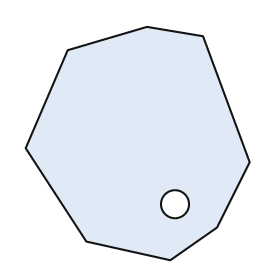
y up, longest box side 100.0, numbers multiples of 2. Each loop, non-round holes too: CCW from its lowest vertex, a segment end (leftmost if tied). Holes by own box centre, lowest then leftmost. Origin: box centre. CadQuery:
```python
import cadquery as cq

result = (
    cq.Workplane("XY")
    .moveTo(14.0, -50.0)
    .lineTo(34.0, -36.0)
    .lineTo(48.0, -8.0)
    .lineTo(28.0, 46.0)
    .lineTo(4.0, 50.0)
    .lineTo(-30.0, 40.0)
    .lineTo(-48.0, -2.0)
    .lineTo(-22.0, -42.0)
    .close()
    .moveTo(16.0, -26.0)
    .circle(6.0)
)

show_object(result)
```